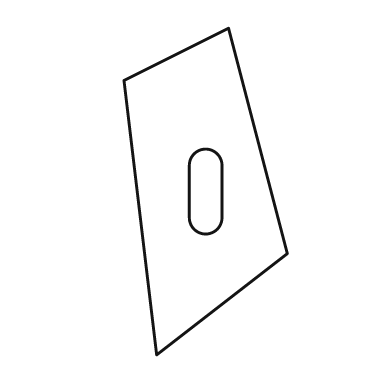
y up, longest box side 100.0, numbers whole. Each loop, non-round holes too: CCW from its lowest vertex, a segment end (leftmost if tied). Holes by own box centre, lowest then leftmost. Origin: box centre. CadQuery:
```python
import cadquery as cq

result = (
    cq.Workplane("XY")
    .moveTo(-15.0, -50.0)
    .lineTo(25.0, -19.0)
    .lineTo(7.0, 50.0)
    .lineTo(-25.0, 34.0)
    .close()
    .moveTo(-5.0, -8.0)
    .threePointArc((0.0, -13.0), (5.0, -8.0))
    .lineTo(5.0, 8.0)
    .threePointArc((0.0, 13.0), (-5.0, 8.0))
    .close()
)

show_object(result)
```